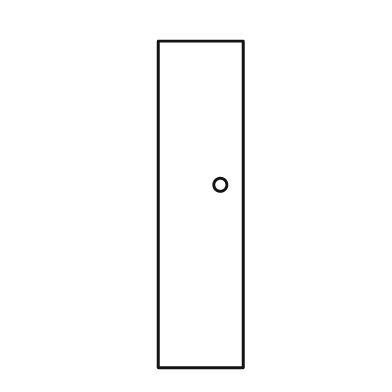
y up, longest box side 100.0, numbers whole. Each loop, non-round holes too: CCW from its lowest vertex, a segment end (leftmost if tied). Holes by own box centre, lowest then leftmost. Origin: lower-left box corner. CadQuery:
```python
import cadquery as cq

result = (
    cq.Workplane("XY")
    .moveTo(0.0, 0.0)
    .lineTo(26.0, 0.0)
    .lineTo(26.0, 100.0)
    .lineTo(0.0, 100.0)
    .close()
    .moveTo(19.0, 56.0)
    .circle(2.0)
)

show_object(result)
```